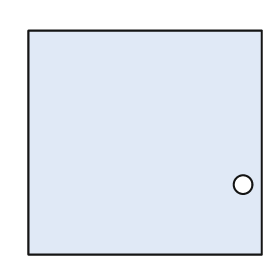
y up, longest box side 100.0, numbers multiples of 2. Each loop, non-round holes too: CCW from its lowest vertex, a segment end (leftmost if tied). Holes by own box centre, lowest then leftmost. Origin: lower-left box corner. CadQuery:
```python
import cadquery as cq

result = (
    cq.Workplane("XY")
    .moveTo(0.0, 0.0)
    .lineTo(100.0, 0.0)
    .lineTo(100.0, 96.0)
    .lineTo(0.0, 96.0)
    .close()
    .moveTo(92.0, 30.0)
    .circle(4.0)
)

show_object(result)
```